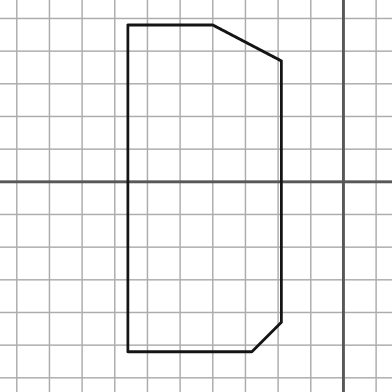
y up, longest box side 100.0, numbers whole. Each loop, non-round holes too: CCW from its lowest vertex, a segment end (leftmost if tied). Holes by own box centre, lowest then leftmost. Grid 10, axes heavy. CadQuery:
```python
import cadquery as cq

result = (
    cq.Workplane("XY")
    .moveTo(-66.0, -52.0)
    .lineTo(-28.0, -52.0)
    .lineTo(-19.0, -43.0)
    .lineTo(-19.0, 37.0)
    .lineTo(-40.0, 48.0)
    .lineTo(-66.0, 48.0)
    .close()
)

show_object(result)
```